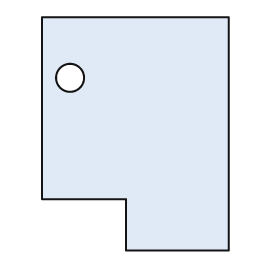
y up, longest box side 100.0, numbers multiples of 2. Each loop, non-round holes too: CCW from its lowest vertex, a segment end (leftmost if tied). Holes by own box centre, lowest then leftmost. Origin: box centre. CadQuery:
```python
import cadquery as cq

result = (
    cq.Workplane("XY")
    .moveTo(-4.0, -50.0)
    .lineTo(40.0, -50.0)
    .lineTo(40.0, 50.0)
    .lineTo(-40.0, 50.0)
    .lineTo(-40.0, -28.0)
    .lineTo(-4.0, -28.0)
    .close()
    .moveTo(-28.0, 24.0)
    .circle(6.0)
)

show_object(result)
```